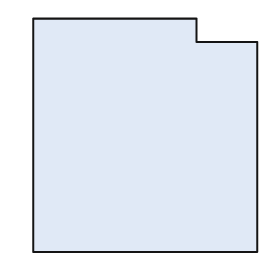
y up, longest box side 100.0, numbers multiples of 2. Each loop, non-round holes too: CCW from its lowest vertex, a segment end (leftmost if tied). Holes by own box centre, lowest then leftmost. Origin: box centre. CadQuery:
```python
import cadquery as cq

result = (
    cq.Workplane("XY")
    .moveTo(-48.0, -50.0)
    .lineTo(48.0, -50.0)
    .lineTo(48.0, 40.0)
    .lineTo(22.0, 40.0)
    .lineTo(22.0, 50.0)
    .lineTo(-48.0, 50.0)
    .close()
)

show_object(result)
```